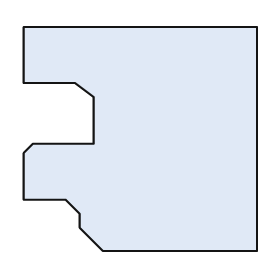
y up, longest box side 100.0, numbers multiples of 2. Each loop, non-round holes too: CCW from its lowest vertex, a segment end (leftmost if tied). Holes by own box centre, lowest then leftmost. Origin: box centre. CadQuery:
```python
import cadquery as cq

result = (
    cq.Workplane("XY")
    .moveTo(-16.0, -48.0)
    .lineTo(50.0, -48.0)
    .lineTo(50.0, 48.0)
    .lineTo(-50.0, 48.0)
    .lineTo(-50.0, 24.0)
    .lineTo(-28.0, 24.0)
    .lineTo(-20.0, 18.0)
    .lineTo(-20.0, -2.0)
    .lineTo(-46.0, -2.0)
    .lineTo(-50.0, -6.0)
    .lineTo(-50.0, -26.0)
    .lineTo(-32.0, -26.0)
    .lineTo(-26.0, -32.0)
    .lineTo(-26.0, -38.0)
    .close()
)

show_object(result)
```